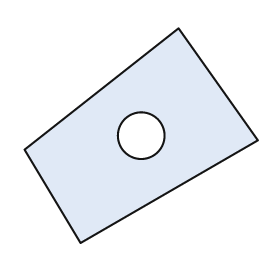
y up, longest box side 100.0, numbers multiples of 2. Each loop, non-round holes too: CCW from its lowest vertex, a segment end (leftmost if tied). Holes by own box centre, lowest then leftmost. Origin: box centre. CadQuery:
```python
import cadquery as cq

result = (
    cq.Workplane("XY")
    .moveTo(-26.0, -46.0)
    .lineTo(50.0, -2.0)
    .lineTo(16.0, 46.0)
    .lineTo(-50.0, -6.0)
    .close()
    .moveTo(0.0, 0.0)
    .circle(10.0)
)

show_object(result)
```